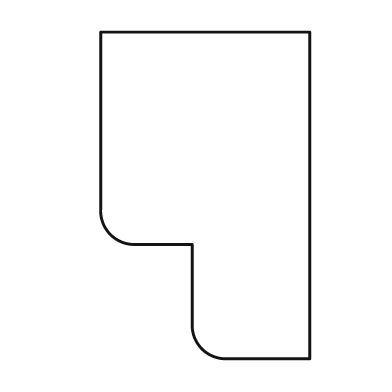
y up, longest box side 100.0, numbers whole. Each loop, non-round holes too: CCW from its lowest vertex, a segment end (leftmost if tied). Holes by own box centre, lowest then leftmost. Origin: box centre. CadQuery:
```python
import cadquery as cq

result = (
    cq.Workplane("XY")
    .moveTo(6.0, -50.0)
    .lineTo(32.0, -50.0)
    .lineTo(32.0, 50.0)
    .lineTo(-32.0, 50.0)
    .lineTo(-32.0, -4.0)
    .threePointArc((-29.0, -12.0), (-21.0, -15.0))
    .lineTo(-4.0, -15.0)
    .lineTo(-4.0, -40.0)
    .threePointArc((-1.0, -47.0), (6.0, -50.0))
    .close()
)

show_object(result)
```